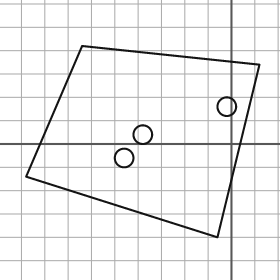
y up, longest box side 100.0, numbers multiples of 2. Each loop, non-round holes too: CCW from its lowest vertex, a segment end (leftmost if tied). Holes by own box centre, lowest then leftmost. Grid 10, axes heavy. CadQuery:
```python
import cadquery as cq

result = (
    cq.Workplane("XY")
    .moveTo(-6.0, -40.0)
    .lineTo(12.0, 34.0)
    .lineTo(-64.0, 42.0)
    .lineTo(-88.0, -14.0)
    .close()
    .moveTo(-46.0, -6.0)
    .circle(4.0)
    .moveTo(-38.0, 4.0)
    .circle(4.0)
    .moveTo(-2.0, 16.0)
    .circle(4.0)
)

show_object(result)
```